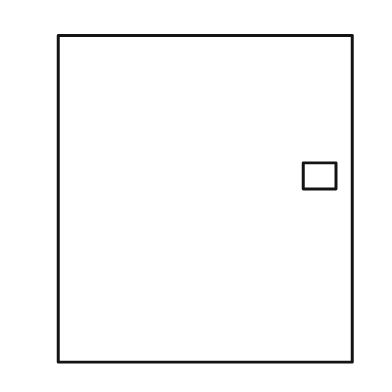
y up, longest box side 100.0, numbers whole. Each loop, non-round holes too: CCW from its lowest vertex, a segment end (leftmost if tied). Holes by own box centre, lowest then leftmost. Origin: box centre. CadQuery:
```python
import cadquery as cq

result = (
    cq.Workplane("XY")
    .moveTo(-45.0, -50.0)
    .lineTo(45.0, -50.0)
    .lineTo(45.0, 50.0)
    .lineTo(-45.0, 50.0)
    .close()
    .moveTo(30.0, 3.0)
    .lineTo(40.0, 3.0)
    .lineTo(40.0, 11.0)
    .lineTo(30.0, 11.0)
    .close()
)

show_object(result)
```